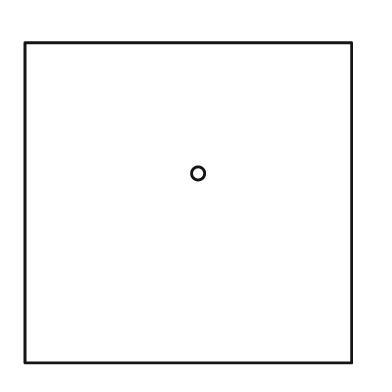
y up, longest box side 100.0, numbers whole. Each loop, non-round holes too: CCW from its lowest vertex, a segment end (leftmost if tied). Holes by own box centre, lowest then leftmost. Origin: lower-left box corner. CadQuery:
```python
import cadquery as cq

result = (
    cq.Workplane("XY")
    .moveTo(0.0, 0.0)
    .lineTo(100.0, 0.0)
    .lineTo(100.0, 98.0)
    .lineTo(0.0, 98.0)
    .close()
    .moveTo(53.0, 58.0)
    .circle(2.0)
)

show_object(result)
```